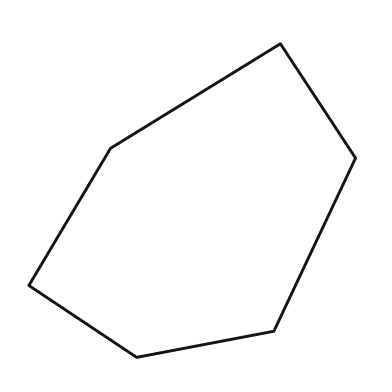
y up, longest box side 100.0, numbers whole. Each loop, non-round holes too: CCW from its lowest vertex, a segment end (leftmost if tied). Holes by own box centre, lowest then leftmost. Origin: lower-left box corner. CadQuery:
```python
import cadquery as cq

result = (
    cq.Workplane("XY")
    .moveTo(33.0, 0.0)
    .lineTo(75.0, 8.0)
    .lineTo(100.0, 61.0)
    .lineTo(77.0, 96.0)
    .lineTo(25.0, 64.0)
    .lineTo(0.0, 22.0)
    .close()
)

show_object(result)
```